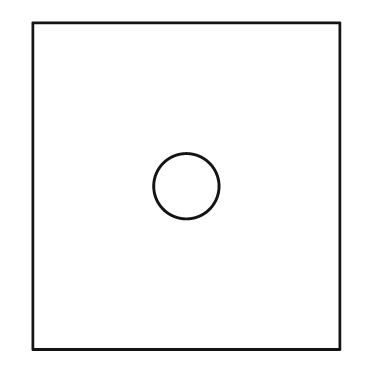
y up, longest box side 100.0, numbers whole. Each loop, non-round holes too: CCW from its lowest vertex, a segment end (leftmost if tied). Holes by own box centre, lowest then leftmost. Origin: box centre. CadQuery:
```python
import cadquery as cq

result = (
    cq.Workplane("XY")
    .moveTo(-47.0, -50.0)
    .lineTo(47.0, -50.0)
    .lineTo(47.0, 50.0)
    .lineTo(-47.0, 50.0)
    .close()
    .moveTo(0.0, 0.0)
    .circle(10.0)
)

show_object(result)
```